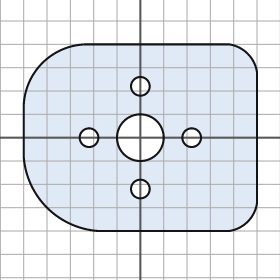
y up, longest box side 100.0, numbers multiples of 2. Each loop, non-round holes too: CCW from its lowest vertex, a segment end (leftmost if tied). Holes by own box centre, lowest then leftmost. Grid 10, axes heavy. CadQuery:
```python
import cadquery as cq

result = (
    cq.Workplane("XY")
    .moveTo(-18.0, -40.0)
    .lineTo(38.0, -40.0)
    .threePointArc((46.0, -36.0), (50.0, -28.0))
    .lineTo(50.0, 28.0)
    .threePointArc((46.0, 36.0), (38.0, 40.0))
    .lineTo(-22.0, 40.0)
    .threePointArc((-42.0, 32.0), (-50.0, 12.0))
    .lineTo(-50.0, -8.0)
    .threePointArc((-40.0, -30.0), (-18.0, -40.0))
    .close()
    .moveTo(0.0, -22.0)
    .circle(4.0)
    .moveTo(-22.0, 0.0)
    .circle(4.0)
    .moveTo(0.0, 0.0)
    .circle(10.0)
    .moveTo(22.0, 0.0)
    .circle(4.0)
    .moveTo(0.0, 22.0)
    .circle(4.0)
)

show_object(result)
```